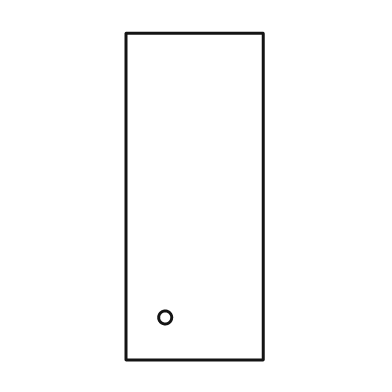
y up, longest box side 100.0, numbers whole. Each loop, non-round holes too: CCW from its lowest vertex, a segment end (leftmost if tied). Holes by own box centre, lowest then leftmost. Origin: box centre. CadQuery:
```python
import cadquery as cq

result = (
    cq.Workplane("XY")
    .moveTo(-21.0, -50.0)
    .lineTo(21.0, -50.0)
    .lineTo(21.0, 50.0)
    .lineTo(-21.0, 50.0)
    .close()
    .moveTo(-9.0, -37.0)
    .circle(2.0)
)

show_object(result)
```